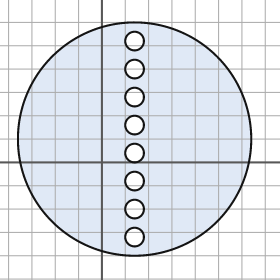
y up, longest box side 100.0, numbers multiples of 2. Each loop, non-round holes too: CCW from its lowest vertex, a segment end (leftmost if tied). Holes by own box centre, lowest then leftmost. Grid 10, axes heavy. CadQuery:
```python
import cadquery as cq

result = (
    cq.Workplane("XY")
    .moveTo(14.0, 10.0)
    .circle(50.0)
    .moveTo(14.0, -32.0)
    .circle(4.0)
    .moveTo(14.0, -20.0)
    .circle(4.0)
    .moveTo(14.0, -8.0)
    .circle(4.0)
    .moveTo(14.0, 4.0)
    .circle(4.0)
    .moveTo(14.0, 16.0)
    .circle(4.0)
    .moveTo(14.0, 28.0)
    .circle(4.0)
    .moveTo(14.0, 40.0)
    .circle(4.0)
    .moveTo(14.0, 52.0)
    .circle(4.0)
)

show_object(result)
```